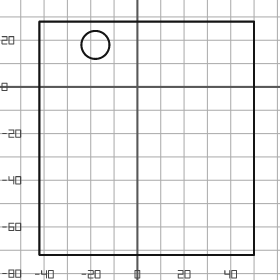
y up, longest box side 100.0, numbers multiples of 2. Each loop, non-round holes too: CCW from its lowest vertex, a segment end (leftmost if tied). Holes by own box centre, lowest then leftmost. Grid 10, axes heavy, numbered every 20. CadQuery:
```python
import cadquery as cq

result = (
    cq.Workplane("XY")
    .moveTo(-42.0, -72.0)
    .lineTo(50.0, -72.0)
    .lineTo(50.0, 28.0)
    .lineTo(-42.0, 28.0)
    .close()
    .moveTo(-18.0, 18.0)
    .circle(6.0)
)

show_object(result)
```